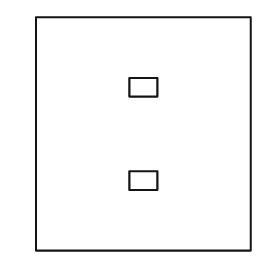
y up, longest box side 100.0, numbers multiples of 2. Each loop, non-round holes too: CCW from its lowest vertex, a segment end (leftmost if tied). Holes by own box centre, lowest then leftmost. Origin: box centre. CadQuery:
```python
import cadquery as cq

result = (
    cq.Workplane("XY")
    .moveTo(-46.0, -50.0)
    .lineTo(46.0, -50.0)
    .lineTo(46.0, 50.0)
    .lineTo(-46.0, 50.0)
    .close()
    .moveTo(-6.0, -24.0)
    .lineTo(6.0, -24.0)
    .lineTo(6.0, -16.0)
    .lineTo(-6.0, -16.0)
    .close()
    .moveTo(-6.0, 16.0)
    .lineTo(6.0, 16.0)
    .lineTo(6.0, 24.0)
    .lineTo(-6.0, 24.0)
    .close()
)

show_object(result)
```